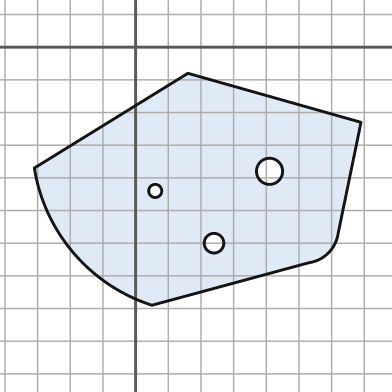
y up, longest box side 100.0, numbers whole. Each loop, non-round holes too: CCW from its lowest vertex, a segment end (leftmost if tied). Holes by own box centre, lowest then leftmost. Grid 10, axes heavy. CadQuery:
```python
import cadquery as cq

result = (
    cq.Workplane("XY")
    .moveTo(5.0, -79.0)
    .lineTo(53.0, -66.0)
    .threePointArc((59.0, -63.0), (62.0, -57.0))
    .lineTo(69.0, -23.0)
    .lineTo(16.0, -8.0)
    .lineTo(-31.0, -37.0)
    .threePointArc((-19.0, -63.0), (5.0, -79.0))
    .close()
    .moveTo(24.0, -60.0)
    .circle(3.0)
    .moveTo(6.0, -44.0)
    .circle(2.0)
    .moveTo(41.0, -38.0)
    .circle(4.0)
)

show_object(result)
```